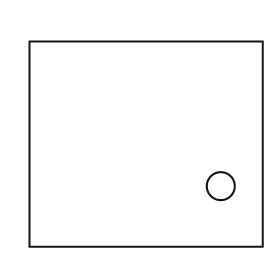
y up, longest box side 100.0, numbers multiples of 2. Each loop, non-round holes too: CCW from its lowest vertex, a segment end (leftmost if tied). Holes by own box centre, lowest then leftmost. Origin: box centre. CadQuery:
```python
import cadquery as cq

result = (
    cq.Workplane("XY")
    .moveTo(-50.0, -44.0)
    .lineTo(50.0, -44.0)
    .lineTo(50.0, 44.0)
    .lineTo(-50.0, 44.0)
    .close()
    .moveTo(32.0, -18.0)
    .circle(6.0)
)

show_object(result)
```